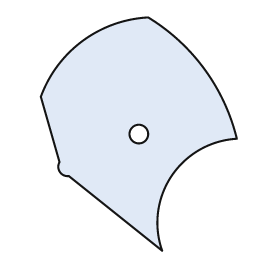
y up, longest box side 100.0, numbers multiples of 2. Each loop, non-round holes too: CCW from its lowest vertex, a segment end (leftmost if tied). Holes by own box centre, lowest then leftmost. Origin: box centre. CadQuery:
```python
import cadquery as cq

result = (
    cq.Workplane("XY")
    .moveTo(10.0, -50.0)
    .threePointArc((14.0, -18.0), (42.0, -2.0))
    .threePointArc((28.0, 28.0), (4.0, 50.0))
    .threePointArc((-24.0, 40.0), (-42.0, 16.0))
    .lineTo(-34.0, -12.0)
    .threePointArc((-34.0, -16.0), (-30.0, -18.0))
    .close()
    .moveTo(0.0, 0.0)
    .circle(4.0)
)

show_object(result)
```